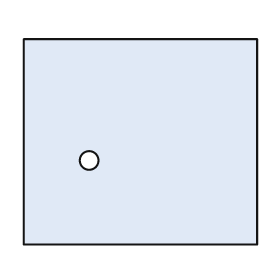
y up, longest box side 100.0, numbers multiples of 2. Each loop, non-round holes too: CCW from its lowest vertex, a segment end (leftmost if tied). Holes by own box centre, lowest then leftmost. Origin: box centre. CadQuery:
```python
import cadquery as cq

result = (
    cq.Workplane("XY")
    .moveTo(-50.0, -44.0)
    .lineTo(50.0, -44.0)
    .lineTo(50.0, 44.0)
    .lineTo(-50.0, 44.0)
    .close()
    .moveTo(-22.0, -8.0)
    .circle(4.0)
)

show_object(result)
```